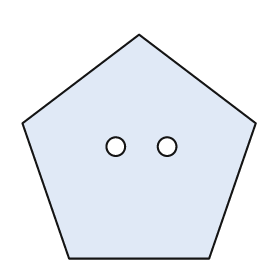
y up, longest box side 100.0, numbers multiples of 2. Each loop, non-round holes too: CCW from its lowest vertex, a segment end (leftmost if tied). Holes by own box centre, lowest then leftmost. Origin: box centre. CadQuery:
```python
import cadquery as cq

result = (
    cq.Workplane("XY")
    .moveTo(-30.0, -48.0)
    .lineTo(30.0, -48.0)
    .lineTo(50.0, 10.0)
    .lineTo(0.0, 48.0)
    .lineTo(-50.0, 10.0)
    .close()
    .moveTo(-10.0, 0.0)
    .circle(4.0)
    .moveTo(12.0, 0.0)
    .circle(4.0)
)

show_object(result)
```